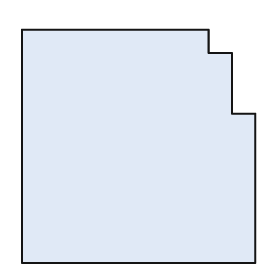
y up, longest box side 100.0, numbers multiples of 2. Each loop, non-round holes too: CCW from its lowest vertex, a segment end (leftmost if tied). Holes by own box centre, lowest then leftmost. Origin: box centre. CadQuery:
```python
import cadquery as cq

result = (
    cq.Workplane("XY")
    .moveTo(-50.0, -50.0)
    .lineTo(50.0, -50.0)
    .lineTo(50.0, 14.0)
    .lineTo(40.0, 14.0)
    .lineTo(40.0, 40.0)
    .lineTo(30.0, 40.0)
    .lineTo(30.0, 50.0)
    .lineTo(-50.0, 50.0)
    .close()
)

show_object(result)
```